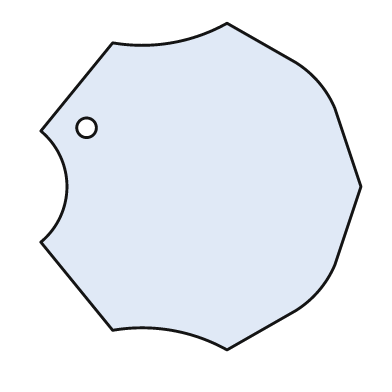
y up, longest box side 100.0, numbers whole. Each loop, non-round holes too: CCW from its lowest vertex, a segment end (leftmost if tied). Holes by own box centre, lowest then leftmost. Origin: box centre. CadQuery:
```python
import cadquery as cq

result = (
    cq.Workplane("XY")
    .moveTo(8.0, -50.0)
    .lineTo(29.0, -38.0)
    .threePointArc((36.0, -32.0), (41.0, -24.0))
    .lineTo(49.0, 0.0)
    .lineTo(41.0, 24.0)
    .threePointArc((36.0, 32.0), (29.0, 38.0))
    .lineTo(8.0, 50.0)
    .threePointArc((-9.0, 44.0), (-27.0, 44.0))
    .lineTo(-49.0, 17.0)
    .threePointArc((-41.0, 0.0), (-49.0, -17.0))
    .lineTo(-27.0, -44.0)
    .threePointArc((-9.0, -44.0), (8.0, -50.0))
    .close()
    .moveTo(-35.0, 18.0)
    .circle(3.0)
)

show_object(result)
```